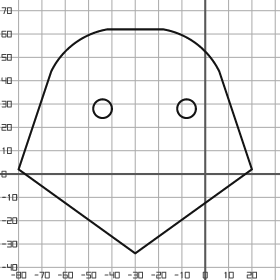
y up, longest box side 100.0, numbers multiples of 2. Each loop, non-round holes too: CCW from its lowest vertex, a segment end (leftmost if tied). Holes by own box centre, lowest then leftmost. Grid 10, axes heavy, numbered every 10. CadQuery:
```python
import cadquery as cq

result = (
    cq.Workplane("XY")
    .moveTo(-30.0, -34.0)
    .lineTo(20.0, 2.0)
    .lineTo(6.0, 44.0)
    .threePointArc((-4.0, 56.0), (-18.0, 62.0))
    .lineTo(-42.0, 62.0)
    .threePointArc((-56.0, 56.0), (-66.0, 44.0))
    .lineTo(-80.0, 2.0)
    .close()
    .moveTo(-44.0, 28.0)
    .circle(4.0)
    .moveTo(-8.0, 28.0)
    .circle(4.0)
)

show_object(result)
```